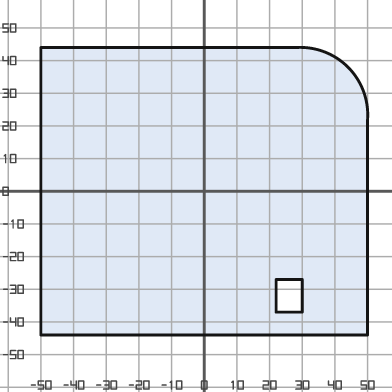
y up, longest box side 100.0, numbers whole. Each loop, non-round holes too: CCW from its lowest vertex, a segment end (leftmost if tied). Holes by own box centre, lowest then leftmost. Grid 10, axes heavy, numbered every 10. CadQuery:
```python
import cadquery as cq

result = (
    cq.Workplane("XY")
    .moveTo(-50.0, -44.0)
    .lineTo(50.0, -44.0)
    .lineTo(50.0, 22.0)
    .threePointArc((44.0, 38.0), (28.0, 44.0))
    .lineTo(-50.0, 44.0)
    .close()
    .moveTo(22.0, -37.0)
    .lineTo(30.0, -37.0)
    .lineTo(30.0, -27.0)
    .lineTo(22.0, -27.0)
    .close()
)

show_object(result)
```